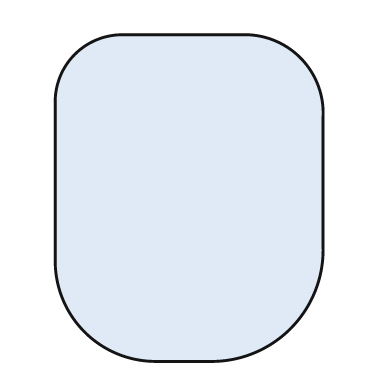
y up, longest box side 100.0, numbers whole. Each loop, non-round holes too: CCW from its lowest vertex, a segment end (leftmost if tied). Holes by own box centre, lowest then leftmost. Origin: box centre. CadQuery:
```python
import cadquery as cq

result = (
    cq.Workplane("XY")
    .moveTo(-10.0, -50.0)
    .lineTo(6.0, -50.0)
    .threePointArc((31.0, -40.0), (41.0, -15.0))
    .lineTo(41.0, 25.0)
    .threePointArc((34.0, 43.0), (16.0, 50.0))
    .lineTo(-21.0, 50.0)
    .threePointArc((-35.0, 44.0), (-41.0, 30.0))
    .lineTo(-41.0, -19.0)
    .threePointArc((-32.0, -41.0), (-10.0, -50.0))
    .close()
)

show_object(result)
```